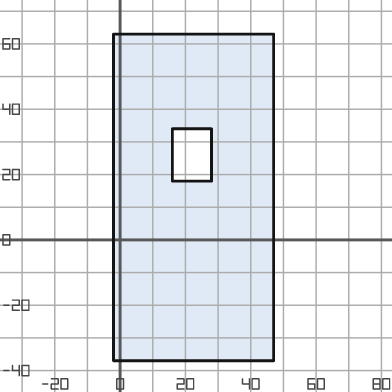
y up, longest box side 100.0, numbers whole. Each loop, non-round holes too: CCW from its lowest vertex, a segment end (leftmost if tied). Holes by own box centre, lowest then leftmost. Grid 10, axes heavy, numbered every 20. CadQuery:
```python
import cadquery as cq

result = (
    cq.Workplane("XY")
    .moveTo(-2.0, -37.0)
    .lineTo(47.0, -37.0)
    .lineTo(47.0, 63.0)
    .lineTo(-2.0, 63.0)
    .close()
    .moveTo(16.0, 18.0)
    .lineTo(28.0, 18.0)
    .lineTo(28.0, 34.0)
    .lineTo(16.0, 34.0)
    .close()
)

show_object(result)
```